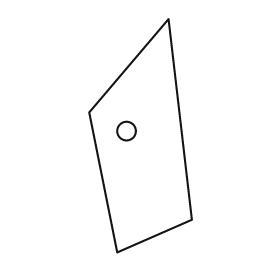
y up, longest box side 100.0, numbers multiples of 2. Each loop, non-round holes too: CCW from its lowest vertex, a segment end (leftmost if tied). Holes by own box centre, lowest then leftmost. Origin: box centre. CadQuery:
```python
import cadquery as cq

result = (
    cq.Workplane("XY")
    .moveTo(-10.0, -50.0)
    .lineTo(22.0, -36.0)
    .lineTo(12.0, 50.0)
    .lineTo(-22.0, 10.0)
    .close()
    .moveTo(-6.0, 2.0)
    .circle(4.0)
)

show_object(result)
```